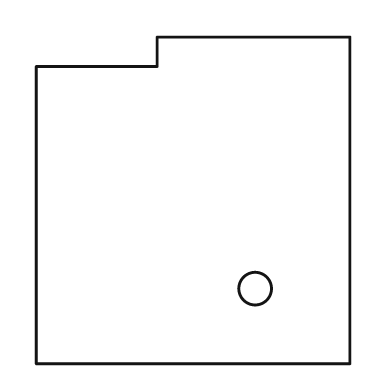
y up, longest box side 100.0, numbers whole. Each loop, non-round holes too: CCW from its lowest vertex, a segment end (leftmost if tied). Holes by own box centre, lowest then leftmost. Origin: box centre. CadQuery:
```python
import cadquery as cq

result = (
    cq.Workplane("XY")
    .moveTo(-48.0, -50.0)
    .lineTo(48.0, -50.0)
    .lineTo(48.0, 50.0)
    .lineTo(-11.0, 50.0)
    .lineTo(-11.0, 41.0)
    .lineTo(-48.0, 41.0)
    .close()
    .moveTo(19.0, -27.0)
    .circle(5.0)
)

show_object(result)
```